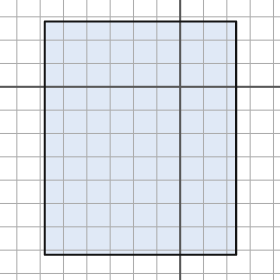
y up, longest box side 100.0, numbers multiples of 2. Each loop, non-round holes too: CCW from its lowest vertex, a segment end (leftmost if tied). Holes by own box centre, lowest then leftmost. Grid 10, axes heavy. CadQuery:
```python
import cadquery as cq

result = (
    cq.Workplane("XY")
    .moveTo(-58.0, -72.0)
    .lineTo(24.0, -72.0)
    .lineTo(24.0, 28.0)
    .lineTo(-58.0, 28.0)
    .close()
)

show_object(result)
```